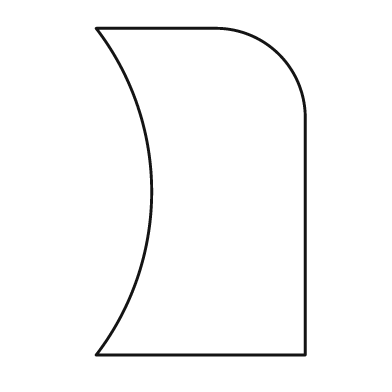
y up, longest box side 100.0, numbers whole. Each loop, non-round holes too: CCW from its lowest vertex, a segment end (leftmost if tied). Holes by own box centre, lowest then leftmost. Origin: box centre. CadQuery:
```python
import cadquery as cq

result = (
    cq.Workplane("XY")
    .moveTo(-32.0, -50.0)
    .lineTo(32.0, -50.0)
    .lineTo(32.0, 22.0)
    .threePointArc((24.0, 42.0), (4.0, 50.0))
    .lineTo(-32.0, 50.0)
    .threePointArc((-15.0, 0.0), (-32.0, -50.0))
    .close()
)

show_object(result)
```